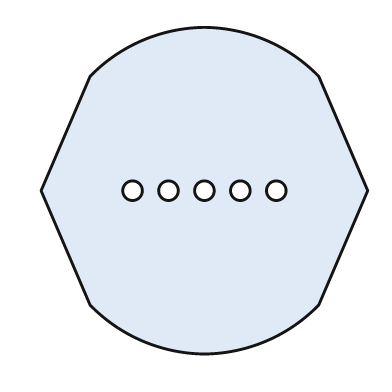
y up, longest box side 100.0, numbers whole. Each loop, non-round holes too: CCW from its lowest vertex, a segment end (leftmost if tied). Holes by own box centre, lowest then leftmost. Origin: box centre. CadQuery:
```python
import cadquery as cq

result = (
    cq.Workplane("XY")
    .moveTo(0.0, -50.0)
    .threePointArc((19.0, -46.0), (35.0, -35.0))
    .lineTo(50.0, 0.0)
    .lineTo(35.0, 35.0)
    .threePointArc((19.0, 46.0), (0.0, 50.0))
    .threePointArc((-19.0, 46.0), (-35.0, 35.0))
    .lineTo(-50.0, 0.0)
    .lineTo(-35.0, -35.0)
    .threePointArc((-19.0, -46.0), (0.0, -50.0))
    .close()
    .moveTo(-22.0, 0.0)
    .circle(3.0)
    .moveTo(-11.0, 0.0)
    .circle(3.0)
    .moveTo(0.0, 0.0)
    .circle(3.0)
    .moveTo(11.0, 0.0)
    .circle(3.0)
    .moveTo(22.0, 0.0)
    .circle(3.0)
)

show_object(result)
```